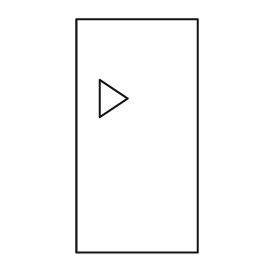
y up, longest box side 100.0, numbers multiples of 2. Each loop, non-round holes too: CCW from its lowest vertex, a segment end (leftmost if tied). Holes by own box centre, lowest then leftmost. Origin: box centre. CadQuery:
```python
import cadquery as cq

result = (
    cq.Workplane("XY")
    .moveTo(-26.0, -50.0)
    .lineTo(26.0, -50.0)
    .lineTo(26.0, 50.0)
    .lineTo(-26.0, 50.0)
    .close()
    .moveTo(-16.0, 8.0)
    .lineTo(-4.0, 16.0)
    .lineTo(-16.0, 24.0)
    .close()
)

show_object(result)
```